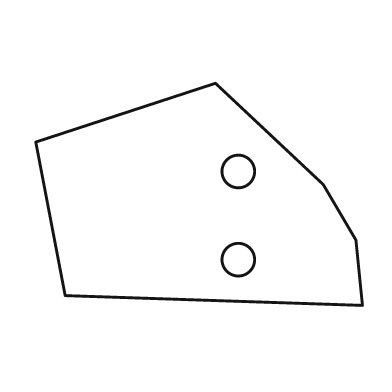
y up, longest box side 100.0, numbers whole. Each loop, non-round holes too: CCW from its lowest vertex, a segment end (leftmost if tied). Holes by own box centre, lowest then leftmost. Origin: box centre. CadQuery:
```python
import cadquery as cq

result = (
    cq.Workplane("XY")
    .moveTo(50.0, -34.0)
    .lineTo(48.0, -14.0)
    .lineTo(38.0, 3.0)
    .lineTo(5.0, 34.0)
    .lineTo(-50.0, 16.0)
    .lineTo(-41.0, -31.0)
    .close()
    .moveTo(12.0, -20.0)
    .circle(5.0)
    .moveTo(12.0, 7.0)
    .circle(5.0)
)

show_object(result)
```